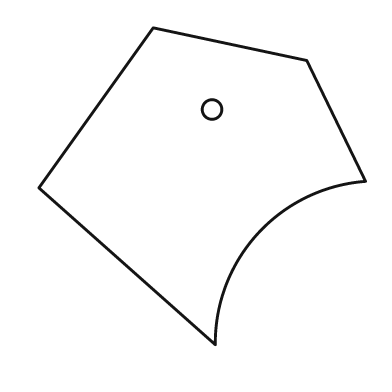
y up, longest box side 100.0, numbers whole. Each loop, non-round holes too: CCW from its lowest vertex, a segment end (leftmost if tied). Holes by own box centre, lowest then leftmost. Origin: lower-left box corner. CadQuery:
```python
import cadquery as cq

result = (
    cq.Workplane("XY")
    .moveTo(54.0, 0.0)
    .threePointArc((67.0, 34.0), (100.0, 50.0))
    .lineTo(82.0, 87.0)
    .lineTo(35.0, 97.0)
    .lineTo(0.0, 48.0)
    .close()
    .moveTo(53.0, 72.0)
    .circle(3.0)
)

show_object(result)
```